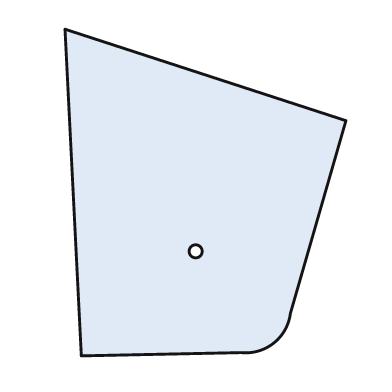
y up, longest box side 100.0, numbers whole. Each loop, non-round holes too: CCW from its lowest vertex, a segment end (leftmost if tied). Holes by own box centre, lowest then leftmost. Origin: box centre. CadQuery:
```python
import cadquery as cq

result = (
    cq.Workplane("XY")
    .moveTo(-38.0, -50.0)
    .lineTo(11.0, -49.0)
    .threePointArc((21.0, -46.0), (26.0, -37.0))
    .lineTo(43.0, 22.0)
    .lineTo(-43.0, 50.0)
    .close()
    .moveTo(-3.0, -18.0)
    .circle(2.0)
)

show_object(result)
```